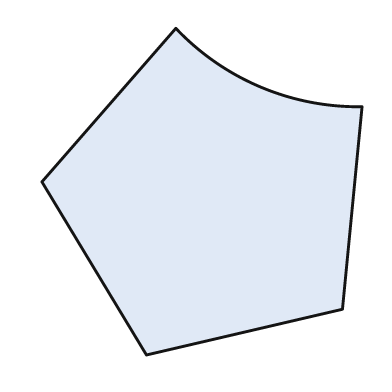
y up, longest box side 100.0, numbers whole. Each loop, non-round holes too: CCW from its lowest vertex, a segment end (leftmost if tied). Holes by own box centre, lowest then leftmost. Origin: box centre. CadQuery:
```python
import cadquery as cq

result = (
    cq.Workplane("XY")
    .moveTo(-17.0, -50.0)
    .lineTo(43.0, -36.0)
    .lineTo(49.0, 26.0)
    .threePointArc((18.0, 32.0), (-8.0, 50.0))
    .lineTo(-49.0, 3.0)
    .close()
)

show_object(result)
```